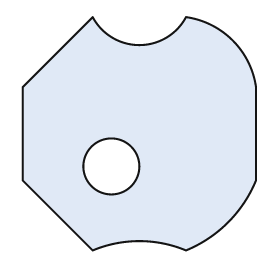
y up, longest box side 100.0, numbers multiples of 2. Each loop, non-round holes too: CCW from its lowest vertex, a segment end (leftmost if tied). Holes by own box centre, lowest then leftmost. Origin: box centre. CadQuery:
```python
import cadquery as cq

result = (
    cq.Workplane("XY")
    .moveTo(-20.0, -50.0)
    .threePointArc((0.0, -46.0), (20.0, -50.0))
    .threePointArc((38.0, -38.0), (50.0, -20.0))
    .lineTo(50.0, 20.0)
    .threePointArc((40.0, 40.0), (20.0, 50.0))
    .threePointArc((0.0, 38.0), (-20.0, 50.0))
    .lineTo(-50.0, 20.0)
    .lineTo(-50.0, -20.0)
    .close()
    .moveTo(-12.0, -14.0)
    .circle(12.0)
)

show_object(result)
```